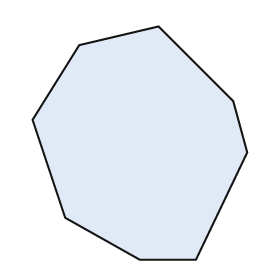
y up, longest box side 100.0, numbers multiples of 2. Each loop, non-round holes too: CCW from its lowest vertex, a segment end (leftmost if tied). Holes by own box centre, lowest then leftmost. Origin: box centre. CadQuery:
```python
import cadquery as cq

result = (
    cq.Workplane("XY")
    .moveTo(0.0, -50.0)
    .lineTo(24.0, -50.0)
    .lineTo(46.0, -4.0)
    .lineTo(40.0, 18.0)
    .lineTo(8.0, 50.0)
    .lineTo(-26.0, 42.0)
    .lineTo(-46.0, 10.0)
    .lineTo(-32.0, -32.0)
    .close()
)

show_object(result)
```